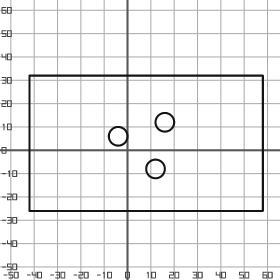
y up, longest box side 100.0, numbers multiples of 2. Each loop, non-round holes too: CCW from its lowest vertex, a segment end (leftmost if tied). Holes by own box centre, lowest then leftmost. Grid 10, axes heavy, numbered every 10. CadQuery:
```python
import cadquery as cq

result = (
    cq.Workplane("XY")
    .moveTo(-42.0, -26.0)
    .lineTo(58.0, -26.0)
    .lineTo(58.0, 32.0)
    .lineTo(-42.0, 32.0)
    .close()
    .moveTo(12.0, -8.0)
    .circle(4.0)
    .moveTo(-4.0, 6.0)
    .circle(4.0)
    .moveTo(16.0, 12.0)
    .circle(4.0)
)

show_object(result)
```